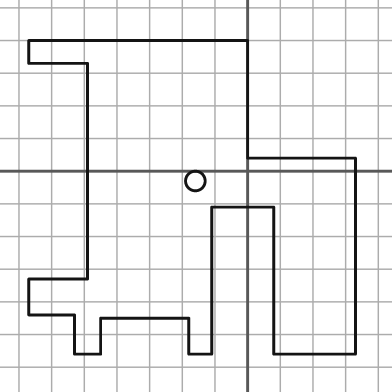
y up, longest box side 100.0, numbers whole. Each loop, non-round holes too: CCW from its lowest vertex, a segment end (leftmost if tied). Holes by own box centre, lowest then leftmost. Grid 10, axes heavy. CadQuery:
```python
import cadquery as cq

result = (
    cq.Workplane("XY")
    .moveTo(-53.0, -56.0)
    .lineTo(-45.0, -56.0)
    .lineTo(-45.0, -45.0)
    .lineTo(-18.0, -45.0)
    .lineTo(-18.0, -56.0)
    .lineTo(-11.0, -56.0)
    .lineTo(-11.0, -11.0)
    .lineTo(8.0, -11.0)
    .lineTo(8.0, -56.0)
    .lineTo(33.0, -56.0)
    .lineTo(33.0, 4.0)
    .lineTo(0.0, 4.0)
    .lineTo(0.0, 40.0)
    .lineTo(-67.0, 40.0)
    .lineTo(-67.0, 33.0)
    .lineTo(-49.0, 33.0)
    .lineTo(-49.0, -33.0)
    .lineTo(-67.0, -33.0)
    .lineTo(-67.0, -44.0)
    .lineTo(-53.0, -44.0)
    .close()
    .moveTo(-16.0, -3.0)
    .circle(3.0)
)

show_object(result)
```